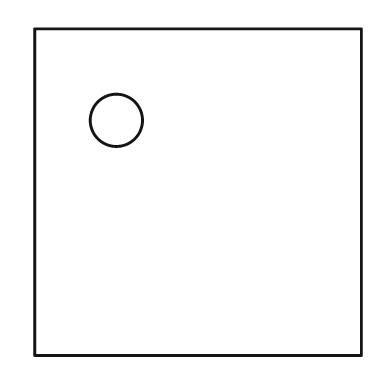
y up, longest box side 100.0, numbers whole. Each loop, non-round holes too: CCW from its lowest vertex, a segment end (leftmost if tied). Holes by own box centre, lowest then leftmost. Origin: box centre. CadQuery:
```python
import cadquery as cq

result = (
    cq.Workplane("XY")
    .moveTo(-50.0, -50.0)
    .lineTo(50.0, -50.0)
    .lineTo(50.0, 50.0)
    .lineTo(-50.0, 50.0)
    .close()
    .moveTo(-25.0, 22.0)
    .circle(8.0)
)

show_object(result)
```